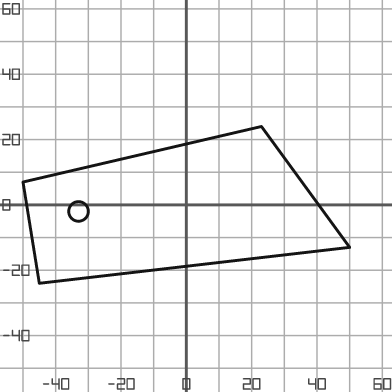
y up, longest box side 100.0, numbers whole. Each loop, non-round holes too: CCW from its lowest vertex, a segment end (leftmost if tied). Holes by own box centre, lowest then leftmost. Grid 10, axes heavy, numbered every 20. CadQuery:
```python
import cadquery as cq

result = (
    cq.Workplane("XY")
    .moveTo(-45.0, -24.0)
    .lineTo(50.0, -13.0)
    .lineTo(23.0, 24.0)
    .lineTo(-50.0, 7.0)
    .close()
    .moveTo(-33.0, -2.0)
    .circle(3.0)
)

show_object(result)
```